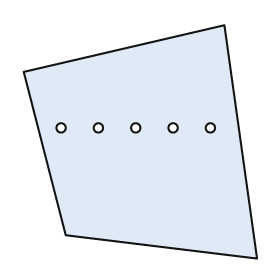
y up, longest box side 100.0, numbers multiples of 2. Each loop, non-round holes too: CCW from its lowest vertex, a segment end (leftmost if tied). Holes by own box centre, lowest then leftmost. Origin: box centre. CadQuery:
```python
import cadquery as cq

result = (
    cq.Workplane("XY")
    .moveTo(50.0, -50.0)
    .lineTo(36.0, 50.0)
    .lineTo(-50.0, 30.0)
    .lineTo(-32.0, -40.0)
    .close()
    .moveTo(-34.0, 6.0)
    .circle(2.0)
    .moveTo(-18.0, 6.0)
    .circle(2.0)
    .moveTo(-2.0, 6.0)
    .circle(2.0)
    .moveTo(14.0, 6.0)
    .circle(2.0)
    .moveTo(30.0, 6.0)
    .circle(2.0)
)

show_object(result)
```